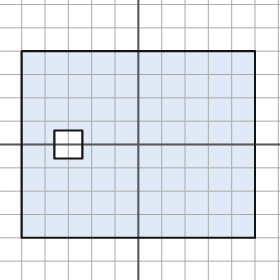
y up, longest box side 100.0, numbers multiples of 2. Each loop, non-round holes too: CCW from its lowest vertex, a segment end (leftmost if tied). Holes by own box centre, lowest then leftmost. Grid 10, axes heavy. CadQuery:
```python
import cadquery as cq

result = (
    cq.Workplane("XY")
    .moveTo(-50.0, -40.0)
    .lineTo(50.0, -40.0)
    .lineTo(50.0, 40.0)
    .lineTo(-50.0, 40.0)
    .close()
    .moveTo(-36.0, -6.0)
    .lineTo(-24.0, -6.0)
    .lineTo(-24.0, 6.0)
    .lineTo(-36.0, 6.0)
    .close()
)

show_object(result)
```